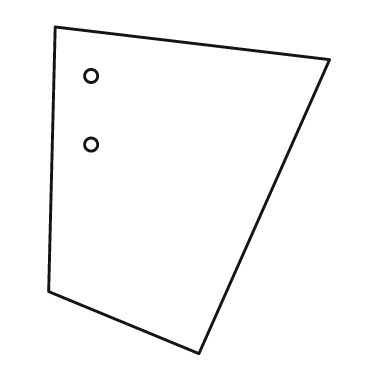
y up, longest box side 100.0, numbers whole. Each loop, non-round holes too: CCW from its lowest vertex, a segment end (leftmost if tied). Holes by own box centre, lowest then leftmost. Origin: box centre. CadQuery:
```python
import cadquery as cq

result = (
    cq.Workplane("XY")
    .moveTo(3.0, -50.0)
    .lineTo(43.0, 40.0)
    .lineTo(-41.0, 50.0)
    .lineTo(-43.0, -31.0)
    .close()
    .moveTo(-30.0, 14.0)
    .circle(2.0)
    .moveTo(-30.0, 35.0)
    .circle(2.0)
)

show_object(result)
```